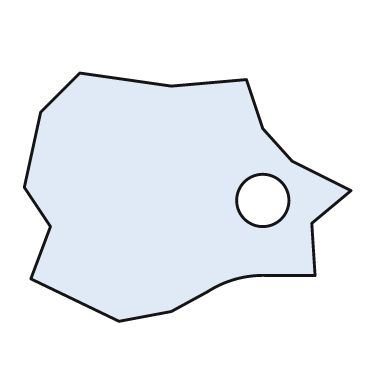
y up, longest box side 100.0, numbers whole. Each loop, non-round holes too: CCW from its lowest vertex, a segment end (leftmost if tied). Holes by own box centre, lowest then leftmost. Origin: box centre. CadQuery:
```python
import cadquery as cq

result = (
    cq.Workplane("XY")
    .moveTo(-21.0, -38.0)
    .lineTo(-5.0, -35.0)
    .lineTo(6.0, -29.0)
    .threePointArc((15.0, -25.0), (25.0, -24.0))
    .lineTo(39.0, -24.0)
    .lineTo(38.0, -8.0)
    .lineTo(50.0, 2.0)
    .lineTo(32.0, 11.0)
    .lineTo(23.0, 21.0)
    .lineTo(18.0, 36.0)
    .lineTo(-5.0, 34.0)
    .lineTo(-33.0, 38.0)
    .lineTo(-45.0, 26.0)
    .lineTo(-50.0, 3.0)
    .lineTo(-42.0, -9.0)
    .lineTo(-48.0, -25.0)
    .close()
    .moveTo(23.0, -1.0)
    .circle(8.0)
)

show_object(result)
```